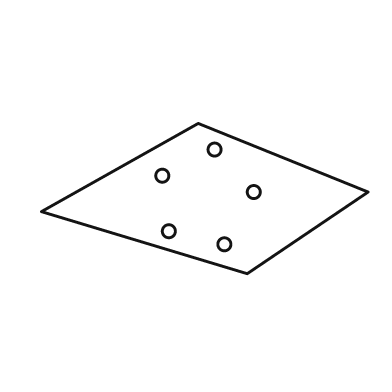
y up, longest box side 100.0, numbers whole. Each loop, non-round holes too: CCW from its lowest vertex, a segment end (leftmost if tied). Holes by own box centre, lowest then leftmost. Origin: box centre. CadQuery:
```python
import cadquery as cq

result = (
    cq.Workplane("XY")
    .moveTo(13.0, -23.0)
    .lineTo(50.0, 2.0)
    .lineTo(-2.0, 23.0)
    .lineTo(-50.0, -4.0)
    .close()
    .moveTo(6.0, -14.0)
    .circle(2.0)
    .moveTo(-11.0, -10.0)
    .circle(2.0)
    .moveTo(15.0, 2.0)
    .circle(2.0)
    .moveTo(-13.0, 7.0)
    .circle(2.0)
    .moveTo(3.0, 15.0)
    .circle(2.0)
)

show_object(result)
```